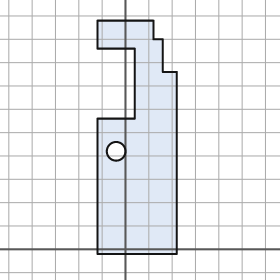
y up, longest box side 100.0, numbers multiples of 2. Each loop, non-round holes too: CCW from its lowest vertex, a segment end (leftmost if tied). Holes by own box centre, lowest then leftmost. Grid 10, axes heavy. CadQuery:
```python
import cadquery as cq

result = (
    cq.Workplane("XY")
    .moveTo(-12.0, -2.0)
    .lineTo(22.0, -2.0)
    .lineTo(22.0, 76.0)
    .lineTo(16.0, 76.0)
    .lineTo(16.0, 90.0)
    .lineTo(12.0, 90.0)
    .lineTo(12.0, 98.0)
    .lineTo(-12.0, 98.0)
    .lineTo(-12.0, 86.0)
    .lineTo(4.0, 86.0)
    .lineTo(4.0, 56.0)
    .lineTo(-12.0, 56.0)
    .close()
    .moveTo(-4.0, 42.0)
    .circle(4.0)
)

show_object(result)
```